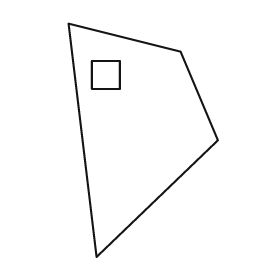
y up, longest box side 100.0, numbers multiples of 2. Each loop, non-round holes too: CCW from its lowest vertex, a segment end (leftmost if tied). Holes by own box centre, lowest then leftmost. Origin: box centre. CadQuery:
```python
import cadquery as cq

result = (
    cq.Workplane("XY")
    .moveTo(-20.0, -50.0)
    .lineTo(32.0, 0.0)
    .lineTo(16.0, 38.0)
    .lineTo(-32.0, 50.0)
    .close()
    .moveTo(-22.0, 22.0)
    .lineTo(-10.0, 22.0)
    .lineTo(-10.0, 34.0)
    .lineTo(-22.0, 34.0)
    .close()
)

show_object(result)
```